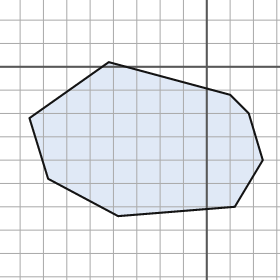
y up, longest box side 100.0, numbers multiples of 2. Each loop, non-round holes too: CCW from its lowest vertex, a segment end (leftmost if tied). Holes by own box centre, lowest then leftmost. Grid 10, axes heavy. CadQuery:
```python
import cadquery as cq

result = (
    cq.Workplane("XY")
    .moveTo(-38.0, -64.0)
    .lineTo(12.0, -60.0)
    .lineTo(24.0, -40.0)
    .lineTo(18.0, -20.0)
    .lineTo(10.0, -12.0)
    .lineTo(-42.0, 2.0)
    .lineTo(-76.0, -22.0)
    .lineTo(-68.0, -48.0)
    .close()
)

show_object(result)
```